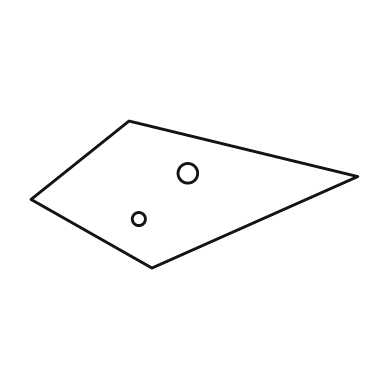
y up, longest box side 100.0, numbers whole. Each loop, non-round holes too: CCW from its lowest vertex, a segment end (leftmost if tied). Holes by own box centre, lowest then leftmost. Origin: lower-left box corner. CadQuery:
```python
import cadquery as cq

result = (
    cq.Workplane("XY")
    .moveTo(37.0, 0.0)
    .lineTo(100.0, 28.0)
    .lineTo(30.0, 45.0)
    .lineTo(0.0, 21.0)
    .close()
    .moveTo(33.0, 15.0)
    .circle(2.0)
    .moveTo(48.0, 29.0)
    .circle(3.0)
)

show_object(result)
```